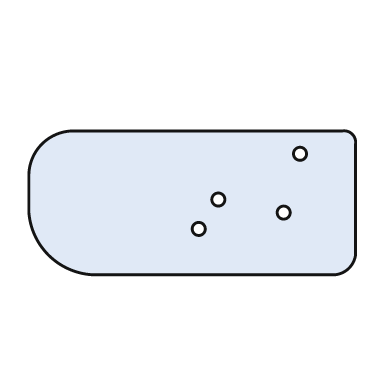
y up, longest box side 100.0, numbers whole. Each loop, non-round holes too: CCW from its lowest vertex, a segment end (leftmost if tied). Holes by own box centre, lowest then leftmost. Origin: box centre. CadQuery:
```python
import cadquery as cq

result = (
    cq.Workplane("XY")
    .moveTo(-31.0, -22.0)
    .lineTo(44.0, -22.0)
    .threePointArc((48.0, -20.0), (50.0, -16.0))
    .lineTo(50.0, 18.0)
    .threePointArc((49.0, 21.0), (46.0, 22.0))
    .lineTo(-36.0, 22.0)
    .threePointArc((-46.0, 18.0), (-50.0, 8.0))
    .lineTo(-50.0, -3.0)
    .threePointArc((-44.0, -16.0), (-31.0, -22.0))
    .close()
    .moveTo(2.0, -8.0)
    .circle(2.0)
    .moveTo(28.0, -3.0)
    .circle(2.0)
    .moveTo(8.0, 1.0)
    .circle(2.0)
    .moveTo(33.0, 15.0)
    .circle(2.0)
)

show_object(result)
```